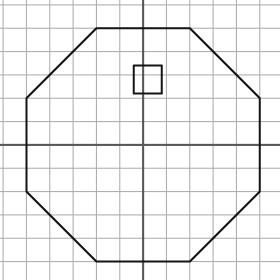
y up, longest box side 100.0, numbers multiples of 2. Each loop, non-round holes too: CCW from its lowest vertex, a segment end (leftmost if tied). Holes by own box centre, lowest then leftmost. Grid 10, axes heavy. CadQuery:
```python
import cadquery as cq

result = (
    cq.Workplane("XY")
    .moveTo(-20.0, -50.0)
    .lineTo(20.0, -50.0)
    .lineTo(50.0, -20.0)
    .lineTo(50.0, 20.0)
    .lineTo(20.0, 50.0)
    .lineTo(-20.0, 50.0)
    .lineTo(-50.0, 20.0)
    .lineTo(-50.0, -20.0)
    .close()
    .moveTo(-4.0, 22.0)
    .lineTo(8.0, 22.0)
    .lineTo(8.0, 34.0)
    .lineTo(-4.0, 34.0)
    .close()
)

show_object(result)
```